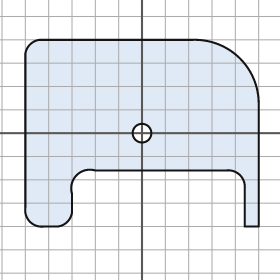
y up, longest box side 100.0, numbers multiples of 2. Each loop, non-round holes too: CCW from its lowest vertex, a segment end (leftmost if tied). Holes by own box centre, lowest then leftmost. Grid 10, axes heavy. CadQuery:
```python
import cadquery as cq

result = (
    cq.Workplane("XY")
    .moveTo(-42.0, -40.0)
    .lineTo(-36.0, -40.0)
    .threePointArc((-32.0, -38.0), (-30.0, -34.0))
    .lineTo(-30.0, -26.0)
    .threePointArc((-28.0, -18.0), (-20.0, -16.0))
    .lineTo(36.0, -16.0)
    .threePointArc((42.0, -18.0), (44.0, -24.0))
    .lineTo(44.0, -40.0)
    .lineTo(50.0, -40.0)
    .lineTo(50.0, 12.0)
    .threePointArc((42.0, 32.0), (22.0, 40.0))
    .lineTo(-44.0, 40.0)
    .threePointArc((-48.0, 38.0), (-50.0, 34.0))
    .lineTo(-50.0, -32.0)
    .threePointArc((-48.0, -38.0), (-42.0, -40.0))
    .close()
    .moveTo(0.0, 0.0)
    .circle(4.0)
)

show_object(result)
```